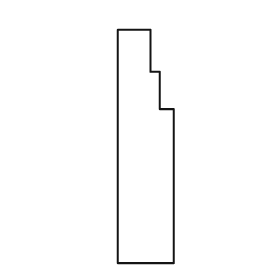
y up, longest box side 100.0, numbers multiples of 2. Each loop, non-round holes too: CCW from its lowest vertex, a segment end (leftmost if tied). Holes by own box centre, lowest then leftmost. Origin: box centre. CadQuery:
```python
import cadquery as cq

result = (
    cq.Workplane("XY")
    .moveTo(-12.0, -50.0)
    .lineTo(12.0, -50.0)
    .lineTo(12.0, 16.0)
    .lineTo(6.0, 16.0)
    .lineTo(6.0, 32.0)
    .lineTo(2.0, 32.0)
    .lineTo(2.0, 50.0)
    .lineTo(-12.0, 50.0)
    .close()
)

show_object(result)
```